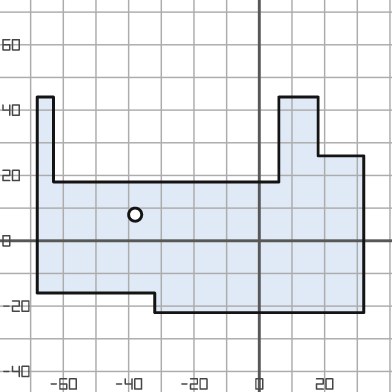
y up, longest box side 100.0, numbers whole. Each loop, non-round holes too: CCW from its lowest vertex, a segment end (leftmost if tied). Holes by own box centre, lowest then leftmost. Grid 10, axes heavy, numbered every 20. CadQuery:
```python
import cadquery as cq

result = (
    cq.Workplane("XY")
    .moveTo(-32.0, -22.0)
    .lineTo(32.0, -22.0)
    .lineTo(32.0, 26.0)
    .lineTo(18.0, 26.0)
    .lineTo(18.0, 44.0)
    .lineTo(6.0, 44.0)
    .lineTo(6.0, 18.0)
    .lineTo(-63.0, 18.0)
    .lineTo(-63.0, 44.0)
    .lineTo(-68.0, 44.0)
    .lineTo(-68.0, -16.0)
    .lineTo(-32.0, -16.0)
    .close()
    .moveTo(-38.0, 8.0)
    .circle(2.0)
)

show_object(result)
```